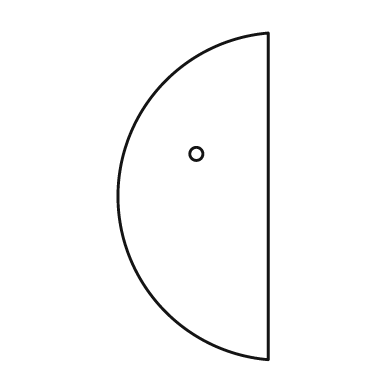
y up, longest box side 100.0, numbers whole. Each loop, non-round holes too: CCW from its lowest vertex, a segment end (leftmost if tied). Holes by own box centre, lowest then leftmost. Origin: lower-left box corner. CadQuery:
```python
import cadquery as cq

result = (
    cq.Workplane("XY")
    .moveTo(46.0, 0.0)
    .lineTo(46.0, 100.0)
    .threePointArc((0.0, 50.0), (46.0, 0.0))
    .close()
    .moveTo(24.0, 63.0)
    .circle(2.0)
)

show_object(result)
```